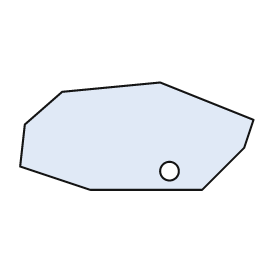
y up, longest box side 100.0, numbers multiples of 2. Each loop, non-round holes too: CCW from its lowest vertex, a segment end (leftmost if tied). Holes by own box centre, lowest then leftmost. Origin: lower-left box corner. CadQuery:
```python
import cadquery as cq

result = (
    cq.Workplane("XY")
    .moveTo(30.0, 0.0)
    .lineTo(78.0, 0.0)
    .lineTo(96.0, 18.0)
    .lineTo(100.0, 30.0)
    .lineTo(60.0, 46.0)
    .lineTo(18.0, 42.0)
    .lineTo(2.0, 28.0)
    .lineTo(0.0, 10.0)
    .close()
    .moveTo(64.0, 8.0)
    .circle(4.0)
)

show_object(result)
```